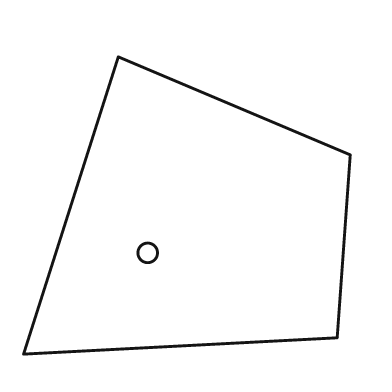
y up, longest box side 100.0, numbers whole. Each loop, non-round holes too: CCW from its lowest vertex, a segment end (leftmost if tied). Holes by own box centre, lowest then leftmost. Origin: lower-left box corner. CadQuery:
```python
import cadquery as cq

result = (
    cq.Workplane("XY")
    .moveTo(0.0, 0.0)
    .lineTo(96.0, 5.0)
    .lineTo(100.0, 61.0)
    .lineTo(29.0, 91.0)
    .close()
    .moveTo(38.0, 31.0)
    .circle(3.0)
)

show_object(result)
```